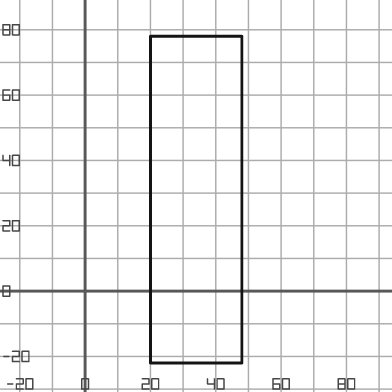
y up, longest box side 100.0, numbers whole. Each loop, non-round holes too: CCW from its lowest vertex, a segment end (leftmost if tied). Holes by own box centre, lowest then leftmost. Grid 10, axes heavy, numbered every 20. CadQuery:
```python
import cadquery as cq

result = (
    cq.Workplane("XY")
    .moveTo(20.0, -22.0)
    .lineTo(48.0, -22.0)
    .lineTo(48.0, 78.0)
    .lineTo(20.0, 78.0)
    .close()
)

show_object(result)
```